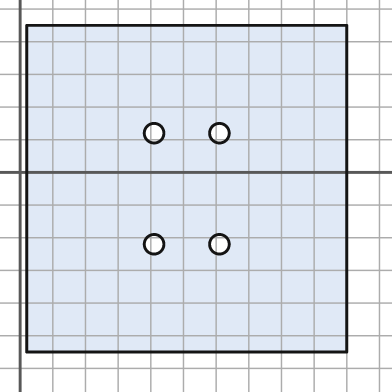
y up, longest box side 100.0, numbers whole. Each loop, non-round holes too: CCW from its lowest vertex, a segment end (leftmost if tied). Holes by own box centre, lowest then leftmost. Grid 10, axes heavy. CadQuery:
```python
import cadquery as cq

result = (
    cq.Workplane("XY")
    .moveTo(2.0, -55.0)
    .lineTo(100.0, -55.0)
    .lineTo(100.0, 45.0)
    .lineTo(2.0, 45.0)
    .close()
    .moveTo(41.0, -22.0)
    .circle(3.0)
    .moveTo(61.0, -22.0)
    .circle(3.0)
    .moveTo(41.0, 12.0)
    .circle(3.0)
    .moveTo(61.0, 12.0)
    .circle(3.0)
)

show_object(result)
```